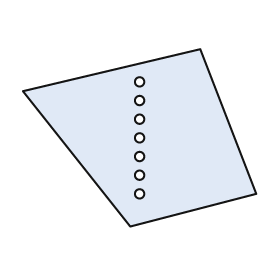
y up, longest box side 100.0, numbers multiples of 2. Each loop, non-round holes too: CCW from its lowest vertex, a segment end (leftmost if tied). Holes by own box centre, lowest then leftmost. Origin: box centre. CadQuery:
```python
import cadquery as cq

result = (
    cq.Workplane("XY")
    .moveTo(-4.0, -38.0)
    .lineTo(50.0, -24.0)
    .lineTo(26.0, 38.0)
    .lineTo(-50.0, 20.0)
    .close()
    .moveTo(0.0, -24.0)
    .circle(2.0)
    .moveTo(0.0, -16.0)
    .circle(2.0)
    .moveTo(0.0, -8.0)
    .circle(2.0)
    .moveTo(0.0, 0.0)
    .circle(2.0)
    .moveTo(0.0, 8.0)
    .circle(2.0)
    .moveTo(0.0, 16.0)
    .circle(2.0)
    .moveTo(0.0, 24.0)
    .circle(2.0)
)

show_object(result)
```